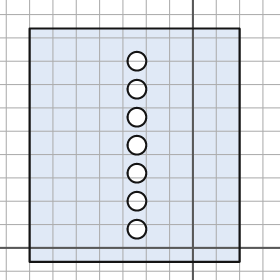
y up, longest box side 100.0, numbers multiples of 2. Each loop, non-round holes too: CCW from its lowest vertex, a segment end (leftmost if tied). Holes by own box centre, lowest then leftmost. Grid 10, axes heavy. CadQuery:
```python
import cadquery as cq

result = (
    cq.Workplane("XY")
    .moveTo(-70.0, -6.0)
    .lineTo(20.0, -6.0)
    .lineTo(20.0, 94.0)
    .lineTo(-70.0, 94.0)
    .close()
    .moveTo(-24.0, 8.0)
    .circle(4.0)
    .moveTo(-24.0, 20.0)
    .circle(4.0)
    .moveTo(-24.0, 32.0)
    .circle(4.0)
    .moveTo(-24.0, 44.0)
    .circle(4.0)
    .moveTo(-24.0, 56.0)
    .circle(4.0)
    .moveTo(-24.0, 68.0)
    .circle(4.0)
    .moveTo(-24.0, 80.0)
    .circle(4.0)
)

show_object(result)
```